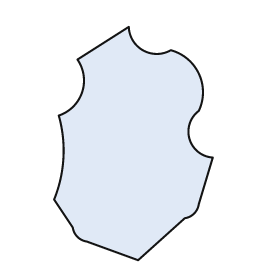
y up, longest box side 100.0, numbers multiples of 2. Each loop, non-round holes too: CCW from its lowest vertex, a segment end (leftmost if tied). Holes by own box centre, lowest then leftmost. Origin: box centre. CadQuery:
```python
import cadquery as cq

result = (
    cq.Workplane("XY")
    .moveTo(2.0, -50.0)
    .lineTo(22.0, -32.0)
    .threePointArc((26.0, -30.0), (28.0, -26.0))
    .lineTo(34.0, -6.0)
    .threePointArc((24.0, 2.0), (28.0, 14.0))
    .threePointArc((28.0, 30.0), (16.0, 40.0))
    .threePointArc((4.0, 40.0), (-2.0, 50.0))
    .lineTo(-24.0, 36.0)
    .threePointArc((-22.0, 22.0), (-32.0, 12.0))
    .threePointArc((-30.0, -6.0), (-34.0, -24.0))
    .lineTo(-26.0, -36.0)
    .threePointArc((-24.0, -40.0), (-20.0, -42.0))
    .close()
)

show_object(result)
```